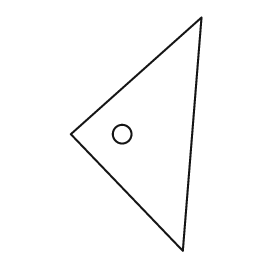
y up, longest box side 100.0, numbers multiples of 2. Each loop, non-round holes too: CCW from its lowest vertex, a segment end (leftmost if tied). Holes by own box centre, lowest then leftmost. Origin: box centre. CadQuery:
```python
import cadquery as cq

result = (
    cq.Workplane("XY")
    .moveTo(20.0, -50.0)
    .lineTo(28.0, 50.0)
    .lineTo(-28.0, 0.0)
    .close()
    .moveTo(-6.0, 0.0)
    .circle(4.0)
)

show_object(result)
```